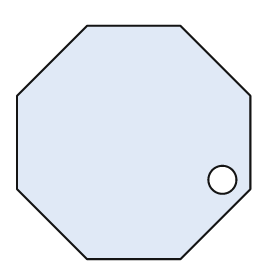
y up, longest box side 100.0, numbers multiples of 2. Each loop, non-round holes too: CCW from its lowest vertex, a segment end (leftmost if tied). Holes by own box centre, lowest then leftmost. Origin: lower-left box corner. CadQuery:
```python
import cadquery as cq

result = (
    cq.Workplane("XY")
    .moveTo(30.0, 0.0)
    .lineTo(70.0, 0.0)
    .lineTo(100.0, 30.0)
    .lineTo(100.0, 70.0)
    .lineTo(70.0, 100.0)
    .lineTo(30.0, 100.0)
    .lineTo(0.0, 70.0)
    .lineTo(0.0, 30.0)
    .close()
    .moveTo(88.0, 34.0)
    .circle(6.0)
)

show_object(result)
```